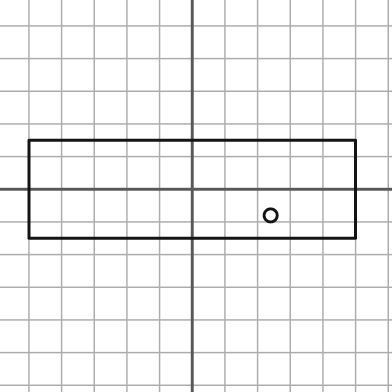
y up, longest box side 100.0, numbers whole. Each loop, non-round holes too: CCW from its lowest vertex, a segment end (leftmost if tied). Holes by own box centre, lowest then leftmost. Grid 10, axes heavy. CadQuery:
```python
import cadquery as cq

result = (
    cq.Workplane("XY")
    .moveTo(-50.0, -15.0)
    .lineTo(50.0, -15.0)
    .lineTo(50.0, 15.0)
    .lineTo(-50.0, 15.0)
    .close()
    .moveTo(24.0, -8.0)
    .circle(2.0)
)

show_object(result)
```